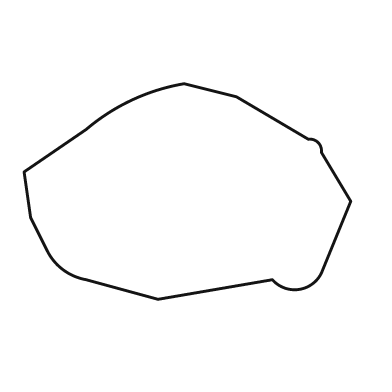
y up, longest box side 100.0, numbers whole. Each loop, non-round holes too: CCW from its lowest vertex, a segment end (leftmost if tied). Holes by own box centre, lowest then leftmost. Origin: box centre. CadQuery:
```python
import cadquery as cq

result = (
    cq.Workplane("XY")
    .moveTo(-9.0, -33.0)
    .lineTo(26.0, -27.0)
    .threePointArc((34.0, -30.0), (41.0, -25.0))
    .lineTo(50.0, -3.0)
    .lineTo(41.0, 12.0)
    .threePointArc((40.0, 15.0), (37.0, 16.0))
    .lineTo(15.0, 29.0)
    .lineTo(-1.0, 33.0)
    .threePointArc((-17.0, 28.0), (-31.0, 19.0))
    .lineTo(-50.0, 6.0)
    .lineTo(-48.0, -8.0)
    .lineTo(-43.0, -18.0)
    .threePointArc((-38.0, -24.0), (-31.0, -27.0))
    .close()
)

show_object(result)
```